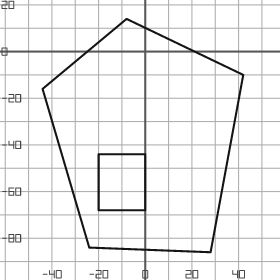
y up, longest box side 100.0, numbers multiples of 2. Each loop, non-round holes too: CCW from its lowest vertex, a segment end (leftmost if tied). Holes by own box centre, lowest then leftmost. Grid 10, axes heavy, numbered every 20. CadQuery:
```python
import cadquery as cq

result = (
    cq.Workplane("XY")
    .moveTo(28.0, -86.0)
    .lineTo(42.0, -10.0)
    .lineTo(-8.0, 14.0)
    .lineTo(-44.0, -16.0)
    .lineTo(-24.0, -84.0)
    .close()
    .moveTo(-20.0, -68.0)
    .lineTo(0.0, -68.0)
    .lineTo(0.0, -44.0)
    .lineTo(-20.0, -44.0)
    .close()
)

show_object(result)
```